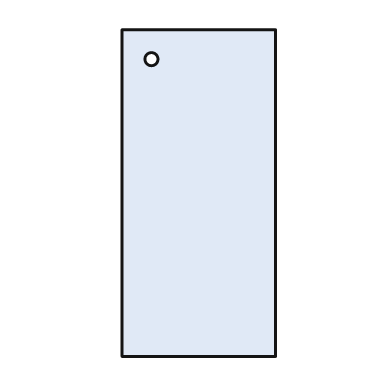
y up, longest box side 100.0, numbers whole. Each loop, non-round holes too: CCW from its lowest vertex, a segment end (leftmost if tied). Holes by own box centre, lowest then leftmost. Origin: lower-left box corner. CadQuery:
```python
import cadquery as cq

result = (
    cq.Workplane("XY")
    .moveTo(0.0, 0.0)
    .lineTo(47.0, 0.0)
    .lineTo(47.0, 100.0)
    .lineTo(0.0, 100.0)
    .close()
    .moveTo(9.0, 91.0)
    .circle(2.0)
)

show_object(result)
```